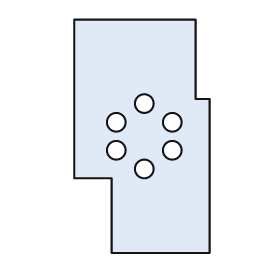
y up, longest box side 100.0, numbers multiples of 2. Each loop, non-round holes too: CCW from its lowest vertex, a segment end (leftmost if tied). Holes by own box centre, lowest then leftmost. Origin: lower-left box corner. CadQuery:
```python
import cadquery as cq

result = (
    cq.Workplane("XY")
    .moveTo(16.0, 0.0)
    .lineTo(58.0, 0.0)
    .lineTo(58.0, 66.0)
    .lineTo(52.0, 66.0)
    .lineTo(52.0, 100.0)
    .lineTo(0.0, 100.0)
    .lineTo(0.0, 32.0)
    .lineTo(16.0, 32.0)
    .close()
    .moveTo(30.0, 36.0)
    .circle(4.0)
    .moveTo(18.0, 44.0)
    .circle(4.0)
    .moveTo(42.0, 44.0)
    .circle(4.0)
    .moveTo(18.0, 56.0)
    .circle(4.0)
    .moveTo(42.0, 56.0)
    .circle(4.0)
    .moveTo(30.0, 64.0)
    .circle(4.0)
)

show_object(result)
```